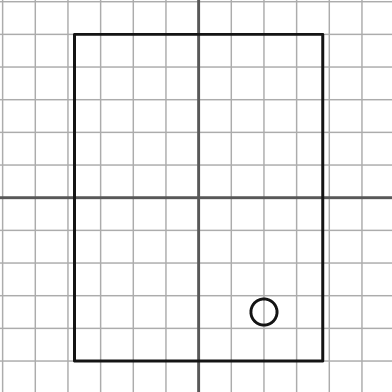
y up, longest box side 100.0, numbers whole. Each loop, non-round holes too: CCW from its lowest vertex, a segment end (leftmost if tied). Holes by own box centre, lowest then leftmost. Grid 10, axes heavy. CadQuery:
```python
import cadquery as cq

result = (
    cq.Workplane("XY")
    .moveTo(-38.0, -50.0)
    .lineTo(38.0, -50.0)
    .lineTo(38.0, 50.0)
    .lineTo(-38.0, 50.0)
    .close()
    .moveTo(20.0, -35.0)
    .circle(4.0)
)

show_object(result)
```